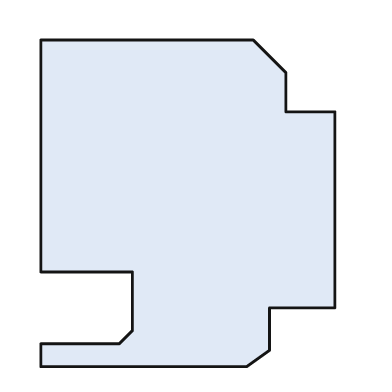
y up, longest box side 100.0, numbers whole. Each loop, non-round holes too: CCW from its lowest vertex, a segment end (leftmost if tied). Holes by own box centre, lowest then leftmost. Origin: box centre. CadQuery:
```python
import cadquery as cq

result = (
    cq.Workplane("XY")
    .moveTo(-45.0, -50.0)
    .lineTo(18.0, -50.0)
    .lineTo(25.0, -45.0)
    .lineTo(25.0, -32.0)
    .lineTo(45.0, -32.0)
    .lineTo(45.0, 28.0)
    .lineTo(30.0, 28.0)
    .lineTo(30.0, 40.0)
    .lineTo(20.0, 50.0)
    .lineTo(-45.0, 50.0)
    .lineTo(-45.0, -21.0)
    .lineTo(-17.0, -21.0)
    .lineTo(-17.0, -39.0)
    .lineTo(-21.0, -43.0)
    .lineTo(-45.0, -43.0)
    .close()
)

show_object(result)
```